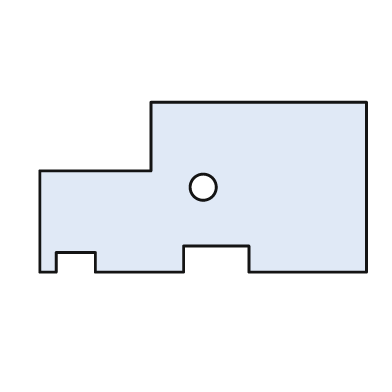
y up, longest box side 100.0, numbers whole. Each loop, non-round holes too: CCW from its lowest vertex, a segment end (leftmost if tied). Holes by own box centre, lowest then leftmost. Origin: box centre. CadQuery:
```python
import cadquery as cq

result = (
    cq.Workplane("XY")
    .moveTo(-50.0, -26.0)
    .lineTo(-45.0, -26.0)
    .lineTo(-45.0, -20.0)
    .lineTo(-33.0, -20.0)
    .lineTo(-33.0, -26.0)
    .lineTo(-6.0, -26.0)
    .lineTo(-6.0, -18.0)
    .lineTo(14.0, -18.0)
    .lineTo(14.0, -26.0)
    .lineTo(50.0, -26.0)
    .lineTo(50.0, 26.0)
    .lineTo(-16.0, 26.0)
    .lineTo(-16.0, 5.0)
    .lineTo(-50.0, 5.0)
    .close()
    .moveTo(0.0, 0.0)
    .circle(4.0)
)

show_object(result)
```